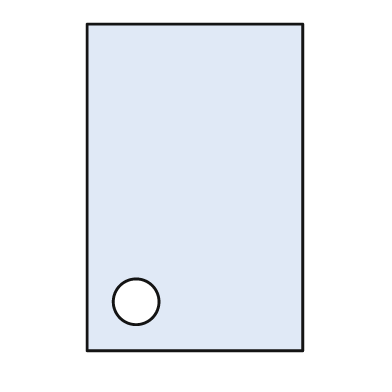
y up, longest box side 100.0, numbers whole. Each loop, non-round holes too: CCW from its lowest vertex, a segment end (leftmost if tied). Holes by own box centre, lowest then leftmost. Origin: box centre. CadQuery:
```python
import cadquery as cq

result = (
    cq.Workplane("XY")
    .moveTo(-33.0, -50.0)
    .lineTo(33.0, -50.0)
    .lineTo(33.0, 50.0)
    .lineTo(-33.0, 50.0)
    .close()
    .moveTo(-18.0, -35.0)
    .circle(7.0)
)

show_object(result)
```